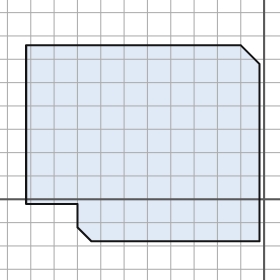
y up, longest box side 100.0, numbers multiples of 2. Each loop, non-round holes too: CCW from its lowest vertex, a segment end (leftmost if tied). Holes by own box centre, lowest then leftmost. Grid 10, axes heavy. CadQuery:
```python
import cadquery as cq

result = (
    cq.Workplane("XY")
    .moveTo(-74.0, -18.0)
    .lineTo(-2.0, -18.0)
    .lineTo(-2.0, 58.0)
    .lineTo(-10.0, 66.0)
    .lineTo(-102.0, 66.0)
    .lineTo(-102.0, -2.0)
    .lineTo(-80.0, -2.0)
    .lineTo(-80.0, -12.0)
    .close()
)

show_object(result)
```